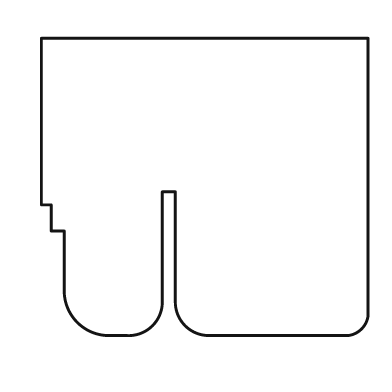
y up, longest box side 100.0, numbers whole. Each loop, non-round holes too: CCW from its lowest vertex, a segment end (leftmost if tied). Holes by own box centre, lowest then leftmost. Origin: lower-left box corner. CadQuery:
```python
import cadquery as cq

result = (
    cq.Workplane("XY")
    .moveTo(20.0, 0.0)
    .lineTo(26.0, 0.0)
    .threePointArc((34.0, 3.0), (37.0, 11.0))
    .lineTo(37.0, 44.0)
    .lineTo(41.0, 44.0)
    .lineTo(41.0, 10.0)
    .threePointArc((44.0, 3.0), (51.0, 0.0))
    .lineTo(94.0, 0.0)
    .threePointArc((98.0, 2.0), (100.0, 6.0))
    .lineTo(100.0, 91.0)
    .lineTo(0.0, 91.0)
    .lineTo(0.0, 40.0)
    .lineTo(3.0, 40.0)
    .lineTo(3.0, 32.0)
    .lineTo(7.0, 32.0)
    .lineTo(7.0, 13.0)
    .threePointArc((11.0, 4.0), (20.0, 0.0))
    .close()
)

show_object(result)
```